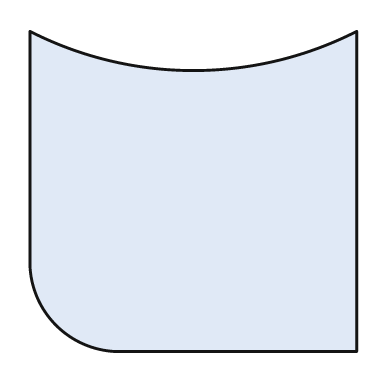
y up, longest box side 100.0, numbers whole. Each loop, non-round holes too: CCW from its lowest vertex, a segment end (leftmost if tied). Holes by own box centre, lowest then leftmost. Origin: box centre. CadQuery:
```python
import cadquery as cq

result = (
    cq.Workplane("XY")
    .moveTo(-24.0, -49.0)
    .lineTo(50.0, -49.0)
    .lineTo(50.0, 49.0)
    .threePointArc((0.0, 37.0), (-50.0, 49.0))
    .lineTo(-50.0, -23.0)
    .threePointArc((-42.0, -41.0), (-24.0, -49.0))
    .close()
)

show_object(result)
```